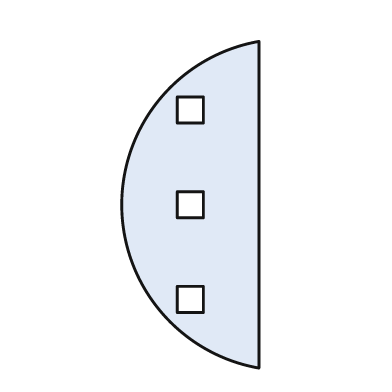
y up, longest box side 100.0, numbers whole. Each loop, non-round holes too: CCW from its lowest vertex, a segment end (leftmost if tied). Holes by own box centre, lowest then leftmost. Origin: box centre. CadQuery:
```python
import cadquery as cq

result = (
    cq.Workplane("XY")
    .moveTo(21.0, -50.0)
    .lineTo(21.0, 50.0)
    .threePointArc((-21.0, 0.0), (21.0, -50.0))
    .close()
    .moveTo(-4.0, -33.0)
    .lineTo(4.0, -33.0)
    .lineTo(4.0, -25.0)
    .lineTo(-4.0, -25.0)
    .close()
    .moveTo(-4.0, -4.0)
    .lineTo(4.0, -4.0)
    .lineTo(4.0, 4.0)
    .lineTo(-4.0, 4.0)
    .close()
    .moveTo(-4.0, 25.0)
    .lineTo(4.0, 25.0)
    .lineTo(4.0, 33.0)
    .lineTo(-4.0, 33.0)
    .close()
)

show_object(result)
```